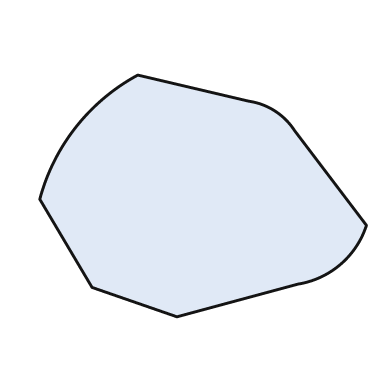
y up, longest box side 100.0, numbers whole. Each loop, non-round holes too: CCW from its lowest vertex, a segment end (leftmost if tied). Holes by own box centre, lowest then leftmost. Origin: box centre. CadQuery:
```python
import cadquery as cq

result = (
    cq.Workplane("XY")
    .moveTo(-8.0, -37.0)
    .lineTo(29.0, -27.0)
    .threePointArc((42.0, -21.0), (50.0, -9.0))
    .lineTo(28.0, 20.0)
    .threePointArc((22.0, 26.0), (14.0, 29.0))
    .lineTo(-20.0, 37.0)
    .threePointArc((-39.0, 21.0), (-50.0, -1.0))
    .lineTo(-34.0, -28.0)
    .close()
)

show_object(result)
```